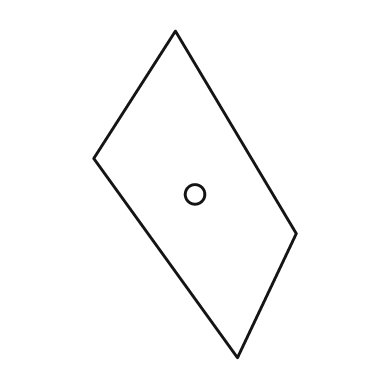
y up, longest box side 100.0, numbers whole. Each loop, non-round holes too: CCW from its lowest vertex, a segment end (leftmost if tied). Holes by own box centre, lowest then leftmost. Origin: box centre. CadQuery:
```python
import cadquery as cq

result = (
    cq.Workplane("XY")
    .moveTo(13.0, -50.0)
    .lineTo(31.0, -12.0)
    .lineTo(-6.0, 50.0)
    .lineTo(-31.0, 11.0)
    .close()
    .moveTo(0.0, 0.0)
    .circle(3.0)
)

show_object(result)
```